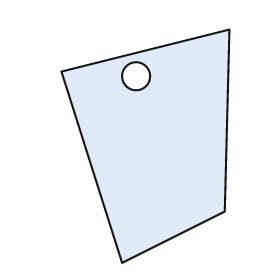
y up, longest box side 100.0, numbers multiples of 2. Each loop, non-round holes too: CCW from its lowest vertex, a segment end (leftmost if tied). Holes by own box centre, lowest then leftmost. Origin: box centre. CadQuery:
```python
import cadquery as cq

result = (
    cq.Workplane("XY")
    .moveTo(-10.0, -50.0)
    .lineTo(34.0, -28.0)
    .lineTo(36.0, 50.0)
    .lineTo(-36.0, 32.0)
    .close()
    .moveTo(-4.0, 30.0)
    .circle(6.0)
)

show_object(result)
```